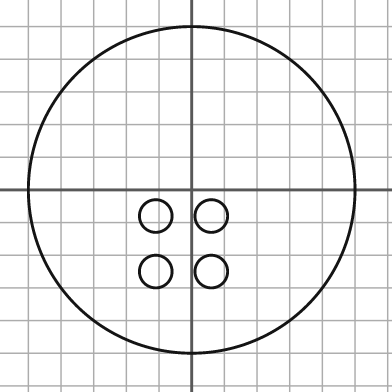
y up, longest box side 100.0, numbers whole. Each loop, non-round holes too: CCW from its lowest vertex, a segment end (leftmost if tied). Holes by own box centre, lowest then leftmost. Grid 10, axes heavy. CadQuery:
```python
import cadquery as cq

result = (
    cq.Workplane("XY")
    .moveTo(0.0, 0.0)
    .circle(50.0)
    .moveTo(-11.0, -25.0)
    .circle(5.0)
    .moveTo(6.0, -25.0)
    .circle(5.0)
    .moveTo(-11.0, -8.0)
    .circle(5.0)
    .moveTo(6.0, -8.0)
    .circle(5.0)
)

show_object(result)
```